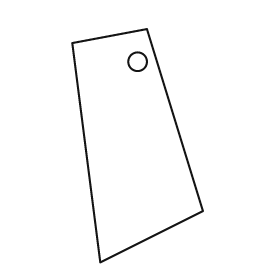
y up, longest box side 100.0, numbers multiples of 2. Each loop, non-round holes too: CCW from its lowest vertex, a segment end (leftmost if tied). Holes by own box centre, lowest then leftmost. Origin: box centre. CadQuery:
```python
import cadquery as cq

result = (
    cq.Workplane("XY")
    .moveTo(-16.0, -50.0)
    .lineTo(28.0, -28.0)
    .lineTo(4.0, 50.0)
    .lineTo(-28.0, 44.0)
    .close()
    .moveTo(0.0, 36.0)
    .circle(4.0)
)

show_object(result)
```